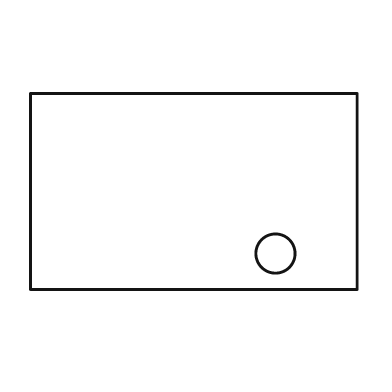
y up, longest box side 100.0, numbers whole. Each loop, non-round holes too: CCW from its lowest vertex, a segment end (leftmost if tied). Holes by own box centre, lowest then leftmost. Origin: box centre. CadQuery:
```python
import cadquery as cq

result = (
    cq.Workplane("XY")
    .moveTo(-50.0, -30.0)
    .lineTo(50.0, -30.0)
    .lineTo(50.0, 30.0)
    .lineTo(-50.0, 30.0)
    .close()
    .moveTo(25.0, -19.0)
    .circle(6.0)
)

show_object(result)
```